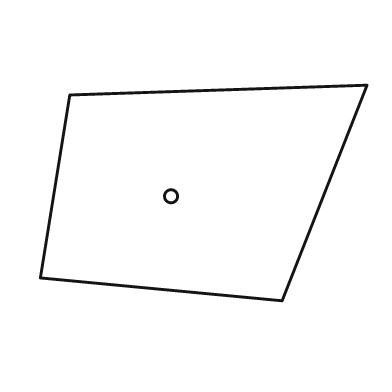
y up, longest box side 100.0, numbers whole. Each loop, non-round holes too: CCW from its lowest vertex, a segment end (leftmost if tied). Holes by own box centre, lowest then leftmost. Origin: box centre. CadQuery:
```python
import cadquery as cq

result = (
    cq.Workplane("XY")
    .moveTo(24.0, -33.0)
    .lineTo(50.0, 33.0)
    .lineTo(-41.0, 30.0)
    .lineTo(-50.0, -26.0)
    .close()
    .moveTo(-10.0, -1.0)
    .circle(2.0)
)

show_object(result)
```